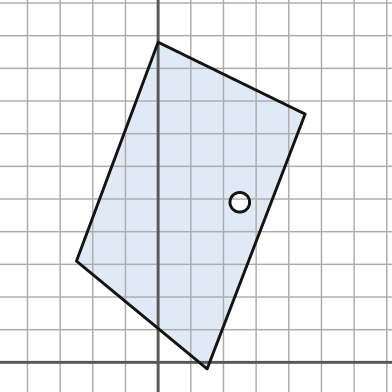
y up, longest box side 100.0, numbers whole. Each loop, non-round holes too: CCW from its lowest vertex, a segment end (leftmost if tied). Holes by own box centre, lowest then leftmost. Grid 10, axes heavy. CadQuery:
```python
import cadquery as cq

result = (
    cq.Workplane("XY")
    .moveTo(15.0, -2.0)
    .lineTo(45.0, 76.0)
    .lineTo(0.0, 98.0)
    .lineTo(-25.0, 31.0)
    .close()
    .moveTo(25.0, 49.0)
    .circle(3.0)
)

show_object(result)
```